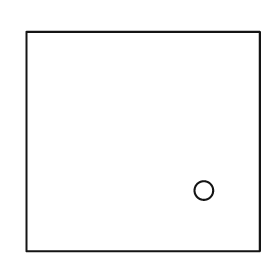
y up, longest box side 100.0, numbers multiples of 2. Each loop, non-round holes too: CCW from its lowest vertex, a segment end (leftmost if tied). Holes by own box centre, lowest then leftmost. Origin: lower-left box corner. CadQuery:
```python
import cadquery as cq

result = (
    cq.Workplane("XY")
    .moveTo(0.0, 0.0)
    .lineTo(100.0, 0.0)
    .lineTo(100.0, 94.0)
    .lineTo(0.0, 94.0)
    .close()
    .moveTo(76.0, 26.0)
    .circle(4.0)
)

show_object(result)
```